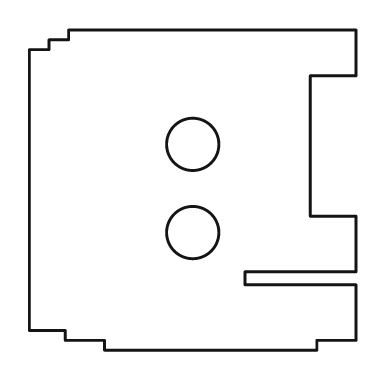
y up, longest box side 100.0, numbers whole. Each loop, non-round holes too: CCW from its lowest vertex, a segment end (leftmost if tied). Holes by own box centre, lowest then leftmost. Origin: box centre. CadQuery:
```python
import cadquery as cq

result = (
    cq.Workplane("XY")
    .moveTo(-27.0, -49.0)
    .lineTo(38.0, -49.0)
    .lineTo(38.0, -46.0)
    .lineTo(50.0, -46.0)
    .lineTo(50.0, -29.0)
    .lineTo(16.0, -29.0)
    .lineTo(16.0, -25.0)
    .lineTo(50.0, -25.0)
    .lineTo(50.0, -8.0)
    .lineTo(36.0, -8.0)
    .lineTo(36.0, 35.0)
    .lineTo(50.0, 35.0)
    .lineTo(50.0, 49.0)
    .lineTo(-38.0, 49.0)
    .lineTo(-38.0, 46.0)
    .lineTo(-44.0, 46.0)
    .lineTo(-44.0, 43.0)
    .lineTo(-50.0, 43.0)
    .lineTo(-50.0, -43.0)
    .lineTo(-39.0, -43.0)
    .lineTo(-39.0, -46.0)
    .lineTo(-27.0, -46.0)
    .close()
    .moveTo(0.0, -13.0)
    .circle(8.0)
    .moveTo(0.0, 14.0)
    .circle(8.0)
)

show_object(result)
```